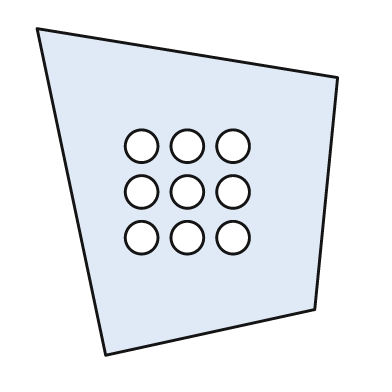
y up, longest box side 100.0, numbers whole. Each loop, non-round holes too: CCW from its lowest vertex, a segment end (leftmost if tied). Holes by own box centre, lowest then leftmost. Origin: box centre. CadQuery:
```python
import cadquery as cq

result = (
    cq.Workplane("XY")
    .moveTo(-25.0, -50.0)
    .lineTo(39.0, -36.0)
    .lineTo(46.0, 35.0)
    .lineTo(-46.0, 50.0)
    .close()
    .moveTo(-14.0, -14.0)
    .circle(5.0)
    .moveTo(0.0, -14.0)
    .circle(5.0)
    .moveTo(14.0, -14.0)
    .circle(5.0)
    .moveTo(-14.0, 0.0)
    .circle(5.0)
    .moveTo(0.0, 0.0)
    .circle(5.0)
    .moveTo(14.0, 0.0)
    .circle(5.0)
    .moveTo(-14.0, 14.0)
    .circle(5.0)
    .moveTo(0.0, 14.0)
    .circle(5.0)
    .moveTo(14.0, 14.0)
    .circle(5.0)
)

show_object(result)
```